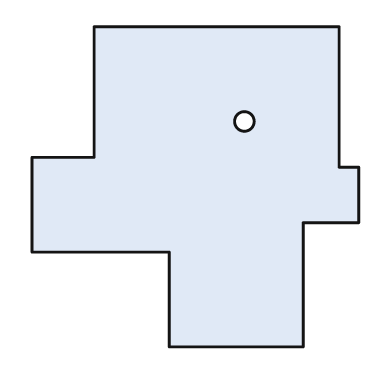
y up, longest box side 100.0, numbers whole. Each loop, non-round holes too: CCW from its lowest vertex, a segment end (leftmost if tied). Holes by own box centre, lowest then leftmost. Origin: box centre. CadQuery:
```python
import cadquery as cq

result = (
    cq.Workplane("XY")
    .moveTo(-8.0, -49.0)
    .lineTo(33.0, -49.0)
    .lineTo(33.0, -11.0)
    .lineTo(50.0, -11.0)
    .lineTo(50.0, 6.0)
    .lineTo(44.0, 6.0)
    .lineTo(44.0, 49.0)
    .lineTo(-31.0, 49.0)
    .lineTo(-31.0, 9.0)
    .lineTo(-50.0, 9.0)
    .lineTo(-50.0, -20.0)
    .lineTo(-8.0, -20.0)
    .close()
    .moveTo(15.0, 20.0)
    .circle(3.0)
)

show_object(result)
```